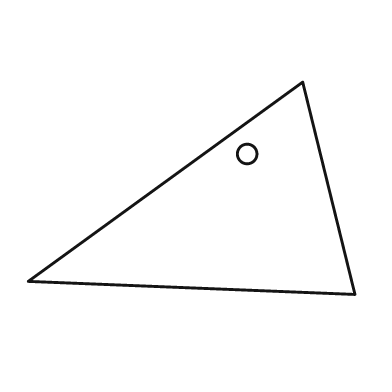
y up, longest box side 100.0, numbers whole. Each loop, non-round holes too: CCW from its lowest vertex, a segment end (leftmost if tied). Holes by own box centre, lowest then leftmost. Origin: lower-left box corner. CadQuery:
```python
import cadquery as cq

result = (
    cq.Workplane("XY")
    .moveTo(100.0, 0.0)
    .lineTo(84.0, 65.0)
    .lineTo(0.0, 4.0)
    .close()
    .moveTo(67.0, 43.0)
    .circle(3.0)
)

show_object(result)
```